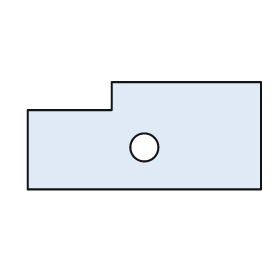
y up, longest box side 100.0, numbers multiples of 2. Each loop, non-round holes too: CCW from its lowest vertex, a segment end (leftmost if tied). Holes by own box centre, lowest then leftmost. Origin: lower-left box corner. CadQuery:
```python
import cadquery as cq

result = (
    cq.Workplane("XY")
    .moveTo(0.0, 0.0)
    .lineTo(100.0, 0.0)
    .lineTo(100.0, 46.0)
    .lineTo(36.0, 46.0)
    .lineTo(36.0, 34.0)
    .lineTo(0.0, 34.0)
    .close()
    .moveTo(50.0, 18.0)
    .circle(6.0)
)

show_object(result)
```